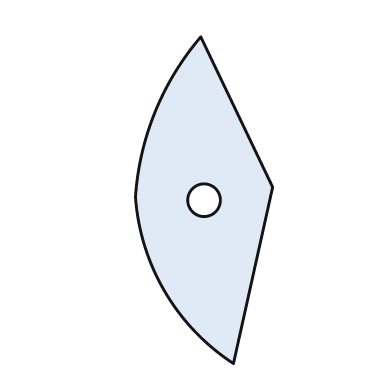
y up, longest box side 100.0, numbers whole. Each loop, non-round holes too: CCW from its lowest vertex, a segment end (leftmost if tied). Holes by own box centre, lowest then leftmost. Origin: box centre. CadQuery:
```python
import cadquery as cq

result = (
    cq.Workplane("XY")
    .moveTo(9.0, -50.0)
    .lineTo(21.0, 4.0)
    .lineTo(-1.0, 50.0)
    .threePointArc((-15.0, 27.0), (-21.0, 1.0))
    .threePointArc((-12.0, -28.0), (9.0, -50.0))
    .close()
    .moveTo(0.0, 0.0)
    .circle(5.0)
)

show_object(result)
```